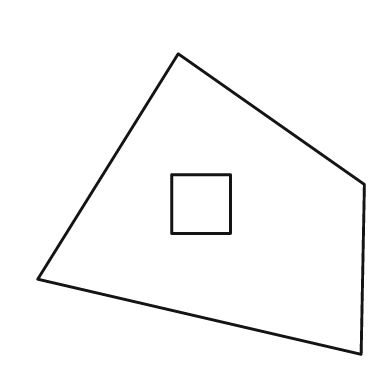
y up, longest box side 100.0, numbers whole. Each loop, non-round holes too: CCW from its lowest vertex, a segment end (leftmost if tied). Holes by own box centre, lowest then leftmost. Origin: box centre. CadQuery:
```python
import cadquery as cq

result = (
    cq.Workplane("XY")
    .moveTo(49.0, -46.0)
    .lineTo(50.0, 6.0)
    .lineTo(-7.0, 46.0)
    .lineTo(-50.0, -23.0)
    .close()
    .moveTo(-9.0, -9.0)
    .lineTo(9.0, -9.0)
    .lineTo(9.0, 9.0)
    .lineTo(-9.0, 9.0)
    .close()
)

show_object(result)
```